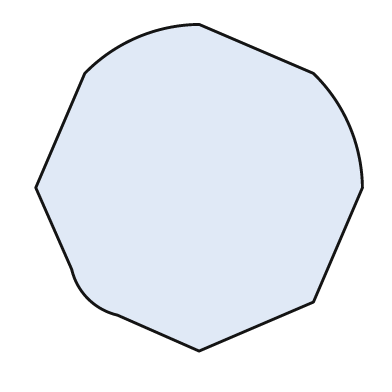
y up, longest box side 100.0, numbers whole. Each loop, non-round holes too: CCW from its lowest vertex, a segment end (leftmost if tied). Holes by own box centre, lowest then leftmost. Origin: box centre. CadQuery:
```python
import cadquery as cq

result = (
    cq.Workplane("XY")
    .moveTo(0.0, -50.0)
    .lineTo(35.0, -35.0)
    .lineTo(50.0, 0.0)
    .threePointArc((46.0, 19.0), (35.0, 35.0))
    .lineTo(0.0, 50.0)
    .threePointArc((-19.0, 46.0), (-35.0, 35.0))
    .lineTo(-50.0, 0.0)
    .lineTo(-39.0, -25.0)
    .threePointArc((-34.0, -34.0), (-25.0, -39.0))
    .close()
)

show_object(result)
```